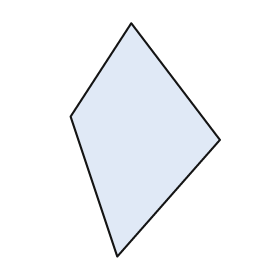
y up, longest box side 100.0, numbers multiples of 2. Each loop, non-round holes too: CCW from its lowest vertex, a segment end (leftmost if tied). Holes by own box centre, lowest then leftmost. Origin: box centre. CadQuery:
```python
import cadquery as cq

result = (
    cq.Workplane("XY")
    .moveTo(-12.0, -50.0)
    .lineTo(32.0, 0.0)
    .lineTo(-6.0, 50.0)
    .lineTo(-32.0, 10.0)
    .close()
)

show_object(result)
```